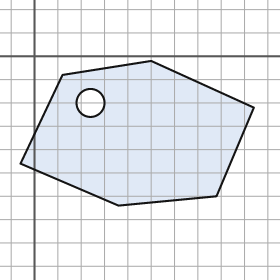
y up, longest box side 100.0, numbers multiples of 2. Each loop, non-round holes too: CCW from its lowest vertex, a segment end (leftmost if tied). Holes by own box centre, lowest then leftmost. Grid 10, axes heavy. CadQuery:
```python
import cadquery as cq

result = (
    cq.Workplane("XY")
    .moveTo(36.0, -64.0)
    .lineTo(78.0, -60.0)
    .lineTo(94.0, -22.0)
    .lineTo(50.0, -2.0)
    .lineTo(12.0, -8.0)
    .lineTo(-6.0, -46.0)
    .close()
    .moveTo(24.0, -20.0)
    .circle(6.0)
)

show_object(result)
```